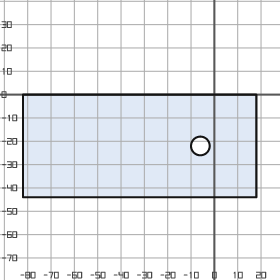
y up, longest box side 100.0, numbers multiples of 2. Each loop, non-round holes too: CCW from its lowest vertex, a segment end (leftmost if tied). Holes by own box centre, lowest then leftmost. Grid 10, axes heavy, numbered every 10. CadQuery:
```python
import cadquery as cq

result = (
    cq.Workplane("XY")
    .moveTo(-82.0, -44.0)
    .lineTo(18.0, -44.0)
    .lineTo(18.0, 0.0)
    .lineTo(-82.0, 0.0)
    .close()
    .moveTo(-6.0, -22.0)
    .circle(4.0)
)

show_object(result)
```